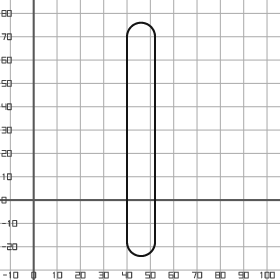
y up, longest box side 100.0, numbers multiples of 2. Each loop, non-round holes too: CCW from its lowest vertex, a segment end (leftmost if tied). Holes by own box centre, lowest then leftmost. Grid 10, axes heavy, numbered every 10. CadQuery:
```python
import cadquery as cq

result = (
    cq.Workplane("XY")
    .moveTo(40.0, -18.0)
    .threePointArc((46.0, -24.0), (52.0, -18.0))
    .lineTo(52.0, 70.0)
    .threePointArc((46.0, 76.0), (40.0, 70.0))
    .close()
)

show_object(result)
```